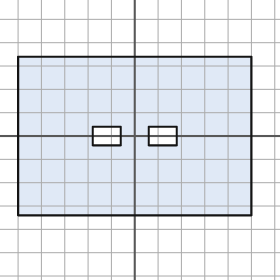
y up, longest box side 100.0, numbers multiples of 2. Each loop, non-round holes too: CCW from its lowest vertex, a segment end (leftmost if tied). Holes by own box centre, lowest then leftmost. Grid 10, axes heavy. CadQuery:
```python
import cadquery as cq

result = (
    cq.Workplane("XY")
    .moveTo(-50.0, -34.0)
    .lineTo(50.0, -34.0)
    .lineTo(50.0, 34.0)
    .lineTo(-50.0, 34.0)
    .close()
    .moveTo(-18.0, -4.0)
    .lineTo(-6.0, -4.0)
    .lineTo(-6.0, 4.0)
    .lineTo(-18.0, 4.0)
    .close()
    .moveTo(6.0, -4.0)
    .lineTo(18.0, -4.0)
    .lineTo(18.0, 4.0)
    .lineTo(6.0, 4.0)
    .close()
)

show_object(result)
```